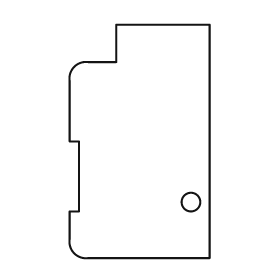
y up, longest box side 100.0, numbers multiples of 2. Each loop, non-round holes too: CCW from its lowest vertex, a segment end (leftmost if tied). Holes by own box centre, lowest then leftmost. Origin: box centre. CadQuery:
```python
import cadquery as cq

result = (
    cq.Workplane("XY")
    .moveTo(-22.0, -50.0)
    .lineTo(30.0, -50.0)
    .lineTo(30.0, 50.0)
    .lineTo(-10.0, 50.0)
    .lineTo(-10.0, 34.0)
    .lineTo(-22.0, 34.0)
    .threePointArc((-28.0, 32.0), (-30.0, 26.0))
    .lineTo(-30.0, 0.0)
    .lineTo(-26.0, 0.0)
    .lineTo(-26.0, -30.0)
    .lineTo(-30.0, -30.0)
    .lineTo(-30.0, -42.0)
    .threePointArc((-28.0, -48.0), (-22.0, -50.0))
    .close()
    .moveTo(22.0, -26.0)
    .circle(4.0)
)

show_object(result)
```